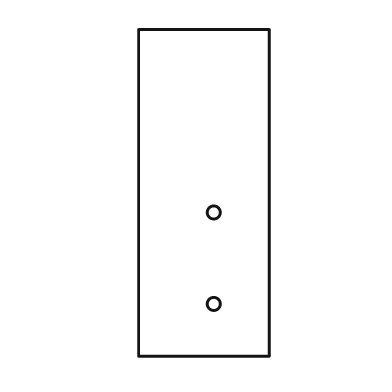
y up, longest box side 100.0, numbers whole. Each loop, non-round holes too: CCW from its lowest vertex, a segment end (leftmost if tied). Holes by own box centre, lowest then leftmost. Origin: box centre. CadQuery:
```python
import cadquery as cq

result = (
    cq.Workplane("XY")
    .moveTo(-20.0, -50.0)
    .lineTo(20.0, -50.0)
    .lineTo(20.0, 50.0)
    .lineTo(-20.0, 50.0)
    .close()
    .moveTo(3.0, -34.0)
    .circle(2.0)
    .moveTo(3.0, -6.0)
    .circle(2.0)
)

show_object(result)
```